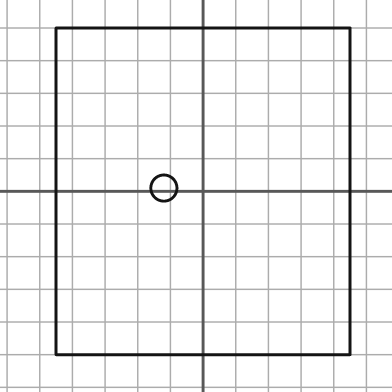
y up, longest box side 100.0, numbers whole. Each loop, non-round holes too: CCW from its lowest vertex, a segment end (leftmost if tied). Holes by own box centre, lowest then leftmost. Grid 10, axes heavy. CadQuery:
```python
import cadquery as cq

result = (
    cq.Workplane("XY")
    .moveTo(-45.0, -50.0)
    .lineTo(45.0, -50.0)
    .lineTo(45.0, 50.0)
    .lineTo(-45.0, 50.0)
    .close()
    .moveTo(-12.0, 1.0)
    .circle(4.0)
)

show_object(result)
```